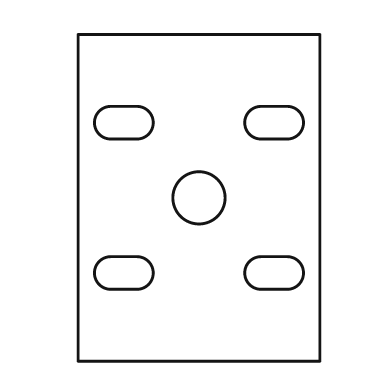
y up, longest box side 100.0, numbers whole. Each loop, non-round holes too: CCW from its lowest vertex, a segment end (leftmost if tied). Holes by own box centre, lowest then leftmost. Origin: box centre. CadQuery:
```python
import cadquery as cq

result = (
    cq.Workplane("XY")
    .moveTo(-37.0, -50.0)
    .lineTo(37.0, -50.0)
    .lineTo(37.0, 50.0)
    .lineTo(-37.0, 50.0)
    .close()
    .moveTo(-27.0, -28.0)
    .lineTo(-19.0, -28.0)
    .threePointArc((-14.0, -23.0), (-19.0, -18.0))
    .lineTo(-27.0, -18.0)
    .threePointArc((-32.0, -23.0), (-27.0, -28.0))
    .close()
    .moveTo(19.0, -28.0)
    .lineTo(27.0, -28.0)
    .threePointArc((32.0, -23.0), (27.0, -18.0))
    .lineTo(19.0, -18.0)
    .threePointArc((14.0, -23.0), (19.0, -28.0))
    .close()
    .moveTo(0.0, 0.0)
    .circle(8.0)
    .moveTo(-27.0, 18.0)
    .lineTo(-19.0, 18.0)
    .threePointArc((-14.0, 23.0), (-19.0, 28.0))
    .lineTo(-27.0, 28.0)
    .threePointArc((-32.0, 23.0), (-27.0, 18.0))
    .close()
    .moveTo(19.0, 18.0)
    .lineTo(27.0, 18.0)
    .threePointArc((32.0, 23.0), (27.0, 28.0))
    .lineTo(19.0, 28.0)
    .threePointArc((14.0, 23.0), (19.0, 18.0))
    .close()
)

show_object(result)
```